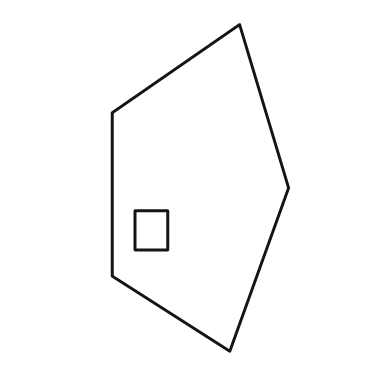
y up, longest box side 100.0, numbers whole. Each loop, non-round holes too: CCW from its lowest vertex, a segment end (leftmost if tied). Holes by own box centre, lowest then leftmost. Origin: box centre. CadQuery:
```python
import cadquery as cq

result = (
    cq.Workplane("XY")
    .moveTo(9.0, -50.0)
    .lineTo(27.0, 0.0)
    .lineTo(12.0, 50.0)
    .lineTo(-27.0, 23.0)
    .lineTo(-27.0, -27.0)
    .close()
    .moveTo(-20.0, -19.0)
    .lineTo(-10.0, -19.0)
    .lineTo(-10.0, -7.0)
    .lineTo(-20.0, -7.0)
    .close()
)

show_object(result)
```